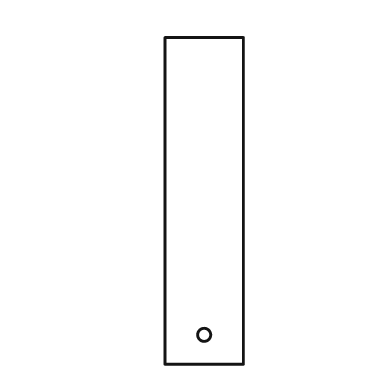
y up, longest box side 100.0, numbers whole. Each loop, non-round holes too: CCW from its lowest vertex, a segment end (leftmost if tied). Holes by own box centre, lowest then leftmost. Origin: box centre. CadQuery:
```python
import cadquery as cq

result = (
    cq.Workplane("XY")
    .moveTo(-12.0, -50.0)
    .lineTo(12.0, -50.0)
    .lineTo(12.0, 50.0)
    .lineTo(-12.0, 50.0)
    .close()
    .moveTo(0.0, -41.0)
    .circle(2.0)
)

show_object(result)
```